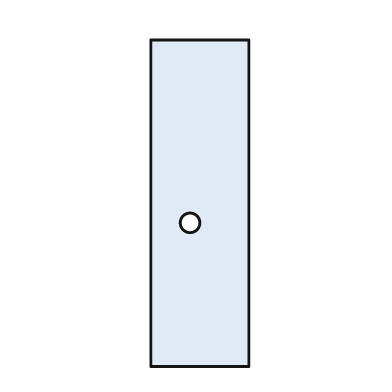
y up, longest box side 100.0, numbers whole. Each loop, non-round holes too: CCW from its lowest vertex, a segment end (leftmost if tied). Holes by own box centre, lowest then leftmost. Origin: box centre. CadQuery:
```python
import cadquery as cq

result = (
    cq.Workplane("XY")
    .moveTo(-15.0, -50.0)
    .lineTo(15.0, -50.0)
    .lineTo(15.0, 50.0)
    .lineTo(-15.0, 50.0)
    .close()
    .moveTo(-3.0, -6.0)
    .circle(3.0)
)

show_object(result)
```